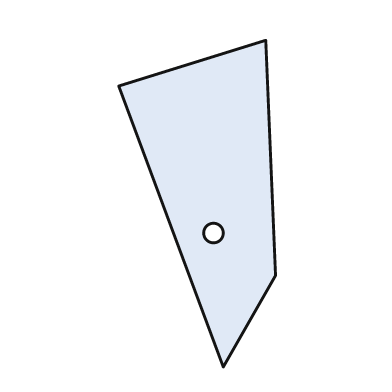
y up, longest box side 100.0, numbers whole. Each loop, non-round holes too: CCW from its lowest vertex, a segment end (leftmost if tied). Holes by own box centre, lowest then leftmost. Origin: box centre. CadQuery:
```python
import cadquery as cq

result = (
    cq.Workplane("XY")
    .moveTo(8.0, -50.0)
    .lineTo(24.0, -22.0)
    .lineTo(21.0, 50.0)
    .lineTo(-24.0, 36.0)
    .close()
    .moveTo(5.0, -9.0)
    .circle(3.0)
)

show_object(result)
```